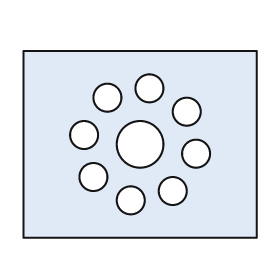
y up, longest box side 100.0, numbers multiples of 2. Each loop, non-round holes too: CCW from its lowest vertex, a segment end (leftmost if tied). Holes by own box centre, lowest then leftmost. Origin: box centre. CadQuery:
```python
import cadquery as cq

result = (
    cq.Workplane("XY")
    .moveTo(-50.0, -40.0)
    .lineTo(50.0, -40.0)
    .lineTo(50.0, 40.0)
    .lineTo(-50.0, 40.0)
    .close()
    .moveTo(-4.0, -24.0)
    .circle(6.0)
    .moveTo(14.0, -20.0)
    .circle(6.0)
    .moveTo(-20.0, -14.0)
    .circle(6.0)
    .moveTo(24.0, -4.0)
    .circle(6.0)
    .moveTo(0.0, 0.0)
    .circle(10.0)
    .moveTo(-24.0, 4.0)
    .circle(6.0)
    .moveTo(20.0, 14.0)
    .circle(6.0)
    .moveTo(-14.0, 20.0)
    .circle(6.0)
    .moveTo(4.0, 24.0)
    .circle(6.0)
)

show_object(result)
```